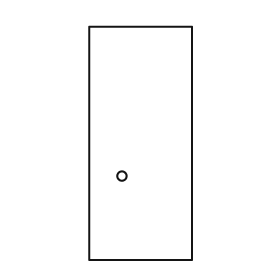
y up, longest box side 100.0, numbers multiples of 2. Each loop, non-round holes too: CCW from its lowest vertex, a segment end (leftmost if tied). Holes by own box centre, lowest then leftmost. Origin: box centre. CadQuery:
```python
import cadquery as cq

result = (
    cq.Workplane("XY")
    .moveTo(-22.0, -50.0)
    .lineTo(22.0, -50.0)
    .lineTo(22.0, 50.0)
    .lineTo(-22.0, 50.0)
    .close()
    .moveTo(-8.0, -14.0)
    .circle(2.0)
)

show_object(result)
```